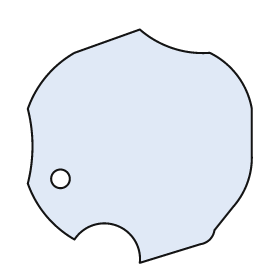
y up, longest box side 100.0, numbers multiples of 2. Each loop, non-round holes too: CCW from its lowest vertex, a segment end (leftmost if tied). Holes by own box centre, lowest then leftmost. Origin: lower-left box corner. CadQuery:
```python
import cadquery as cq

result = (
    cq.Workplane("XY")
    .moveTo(48.0, 0.0)
    .lineTo(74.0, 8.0)
    .threePointArc((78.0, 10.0), (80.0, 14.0))
    .lineTo(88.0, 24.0)
    .threePointArc((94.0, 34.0), (96.0, 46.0))
    .lineTo(96.0, 66.0)
    .threePointArc((90.0, 80.0), (78.0, 90.0))
    .threePointArc((62.0, 92.0), (48.0, 100.0))
    .lineTo(20.0, 90.0)
    .threePointArc((8.0, 80.0), (0.0, 66.0))
    .threePointArc((2.0, 50.0), (0.0, 34.0))
    .threePointArc((8.0, 20.0), (20.0, 10.0))
    .threePointArc((38.0, 16.0), (48.0, 0.0))
    .close()
    .moveTo(14.0, 36.0)
    .circle(4.0)
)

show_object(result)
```